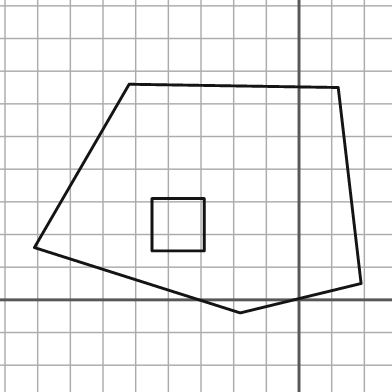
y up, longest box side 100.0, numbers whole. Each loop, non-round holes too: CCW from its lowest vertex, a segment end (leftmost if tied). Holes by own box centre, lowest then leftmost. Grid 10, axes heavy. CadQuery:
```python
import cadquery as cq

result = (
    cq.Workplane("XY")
    .moveTo(-18.0, -4.0)
    .lineTo(19.0, 5.0)
    .lineTo(12.0, 65.0)
    .lineTo(-52.0, 66.0)
    .lineTo(-81.0, 16.0)
    .close()
    .moveTo(-45.0, 15.0)
    .lineTo(-29.0, 15.0)
    .lineTo(-29.0, 31.0)
    .lineTo(-45.0, 31.0)
    .close()
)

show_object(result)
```